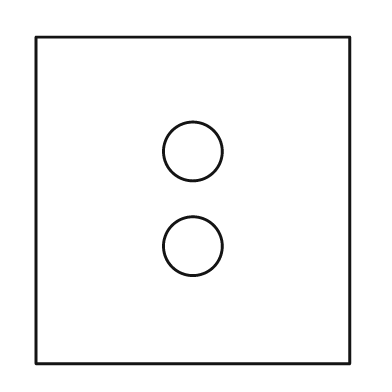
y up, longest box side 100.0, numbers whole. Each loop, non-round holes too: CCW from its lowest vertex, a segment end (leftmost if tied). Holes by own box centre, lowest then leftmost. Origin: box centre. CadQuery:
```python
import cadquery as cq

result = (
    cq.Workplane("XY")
    .moveTo(-48.0, -50.0)
    .lineTo(48.0, -50.0)
    .lineTo(48.0, 50.0)
    .lineTo(-48.0, 50.0)
    .close()
    .moveTo(0.0, -14.0)
    .circle(9.0)
    .moveTo(0.0, 15.0)
    .circle(9.0)
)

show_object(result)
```